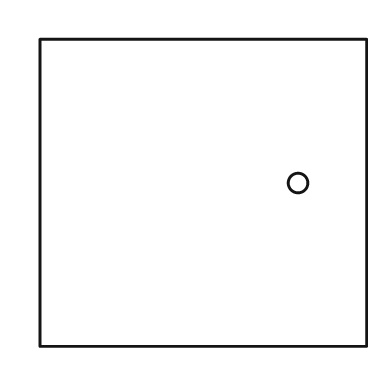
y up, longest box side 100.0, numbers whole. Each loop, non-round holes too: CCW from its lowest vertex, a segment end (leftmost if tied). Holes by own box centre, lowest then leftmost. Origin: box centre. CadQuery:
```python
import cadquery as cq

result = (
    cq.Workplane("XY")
    .moveTo(-50.0, -47.0)
    .lineTo(50.0, -47.0)
    .lineTo(50.0, 47.0)
    .lineTo(-50.0, 47.0)
    .close()
    .moveTo(29.0, 3.0)
    .circle(3.0)
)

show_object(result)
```